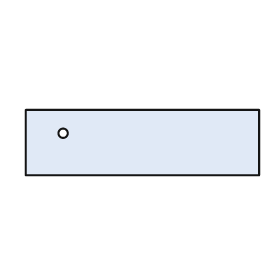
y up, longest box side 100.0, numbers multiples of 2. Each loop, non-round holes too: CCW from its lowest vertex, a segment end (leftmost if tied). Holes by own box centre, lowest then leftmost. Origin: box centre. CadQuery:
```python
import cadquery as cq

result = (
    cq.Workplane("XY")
    .moveTo(-50.0, -14.0)
    .lineTo(50.0, -14.0)
    .lineTo(50.0, 14.0)
    .lineTo(-50.0, 14.0)
    .close()
    .moveTo(-34.0, 4.0)
    .circle(2.0)
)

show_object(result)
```